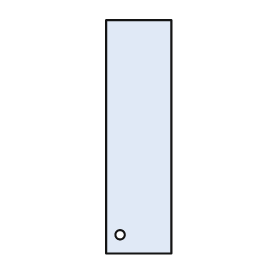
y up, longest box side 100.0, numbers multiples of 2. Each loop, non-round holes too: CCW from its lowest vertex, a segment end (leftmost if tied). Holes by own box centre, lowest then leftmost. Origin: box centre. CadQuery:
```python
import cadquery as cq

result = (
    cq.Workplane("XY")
    .moveTo(-14.0, -50.0)
    .lineTo(14.0, -50.0)
    .lineTo(14.0, 50.0)
    .lineTo(-14.0, 50.0)
    .close()
    .moveTo(-8.0, -42.0)
    .circle(2.0)
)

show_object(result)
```